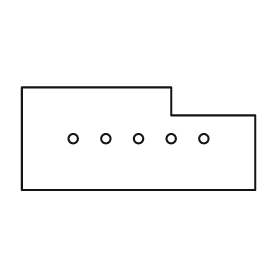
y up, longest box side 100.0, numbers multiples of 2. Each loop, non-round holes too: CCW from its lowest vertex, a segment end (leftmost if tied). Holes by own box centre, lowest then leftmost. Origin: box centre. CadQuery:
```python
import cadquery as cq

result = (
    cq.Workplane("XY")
    .moveTo(-50.0, -22.0)
    .lineTo(50.0, -22.0)
    .lineTo(50.0, 10.0)
    .lineTo(14.0, 10.0)
    .lineTo(14.0, 22.0)
    .lineTo(-50.0, 22.0)
    .close()
    .moveTo(-28.0, 0.0)
    .circle(2.0)
    .moveTo(-14.0, 0.0)
    .circle(2.0)
    .moveTo(0.0, 0.0)
    .circle(2.0)
    .moveTo(14.0, 0.0)
    .circle(2.0)
    .moveTo(28.0, 0.0)
    .circle(2.0)
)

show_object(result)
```